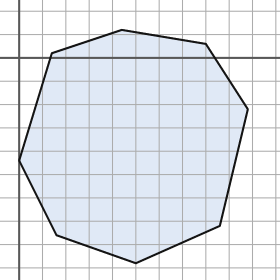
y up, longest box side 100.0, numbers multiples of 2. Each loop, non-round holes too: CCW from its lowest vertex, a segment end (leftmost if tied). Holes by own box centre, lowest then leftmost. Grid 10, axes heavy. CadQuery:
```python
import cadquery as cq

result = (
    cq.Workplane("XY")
    .moveTo(50.0, -88.0)
    .lineTo(86.0, -72.0)
    .lineTo(98.0, -22.0)
    .lineTo(80.0, 6.0)
    .lineTo(44.0, 12.0)
    .lineTo(14.0, 2.0)
    .lineTo(0.0, -44.0)
    .lineTo(16.0, -76.0)
    .close()
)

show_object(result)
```